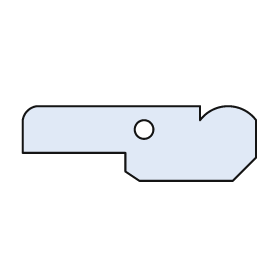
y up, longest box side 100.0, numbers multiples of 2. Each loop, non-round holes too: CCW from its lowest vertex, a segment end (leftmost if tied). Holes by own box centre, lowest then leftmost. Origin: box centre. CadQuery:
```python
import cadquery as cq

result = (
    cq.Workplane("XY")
    .moveTo(0.0, -16.0)
    .lineTo(40.0, -16.0)
    .lineTo(50.0, -6.0)
    .lineTo(50.0, 10.0)
    .threePointArc((38.0, 16.0), (26.0, 10.0))
    .lineTo(26.0, 16.0)
    .lineTo(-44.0, 16.0)
    .threePointArc((-48.0, 14.0), (-50.0, 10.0))
    .lineTo(-50.0, -4.0)
    .lineTo(-6.0, -4.0)
    .lineTo(-6.0, -12.0)
    .close()
    .moveTo(2.0, 6.0)
    .circle(4.0)
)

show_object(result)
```